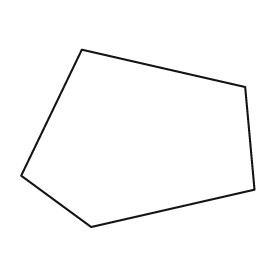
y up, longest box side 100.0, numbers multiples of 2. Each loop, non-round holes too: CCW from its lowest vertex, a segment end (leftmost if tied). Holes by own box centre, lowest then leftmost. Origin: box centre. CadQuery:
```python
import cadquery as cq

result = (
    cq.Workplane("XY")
    .moveTo(-20.0, -38.0)
    .lineTo(50.0, -22.0)
    .lineTo(46.0, 22.0)
    .lineTo(-24.0, 38.0)
    .lineTo(-50.0, -16.0)
    .close()
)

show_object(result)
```